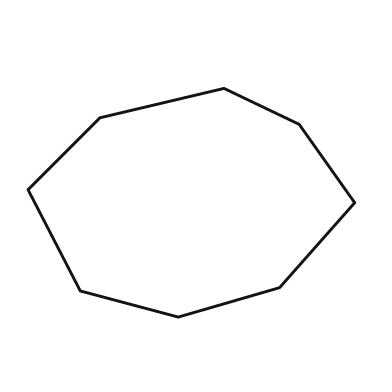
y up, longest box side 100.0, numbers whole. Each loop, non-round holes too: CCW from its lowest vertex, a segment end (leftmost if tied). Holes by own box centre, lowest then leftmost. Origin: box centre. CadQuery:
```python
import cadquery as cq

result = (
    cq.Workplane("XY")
    .moveTo(-4.0, -35.0)
    .lineTo(27.0, -26.0)
    .lineTo(50.0, 0.0)
    .lineTo(33.0, 24.0)
    .lineTo(10.0, 35.0)
    .lineTo(-28.0, 26.0)
    .lineTo(-50.0, 4.0)
    .lineTo(-34.0, -27.0)
    .close()
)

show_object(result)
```